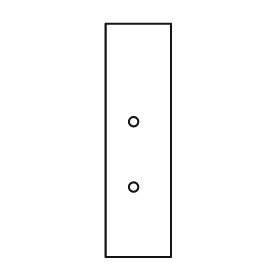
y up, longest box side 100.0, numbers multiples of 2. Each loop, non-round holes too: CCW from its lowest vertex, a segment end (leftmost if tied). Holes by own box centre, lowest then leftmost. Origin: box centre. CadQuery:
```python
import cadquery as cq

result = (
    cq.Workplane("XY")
    .moveTo(-14.0, -50.0)
    .lineTo(14.0, -50.0)
    .lineTo(14.0, 50.0)
    .lineTo(-14.0, 50.0)
    .close()
    .moveTo(-2.0, -20.0)
    .circle(2.0)
    .moveTo(-2.0, 8.0)
    .circle(2.0)
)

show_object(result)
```